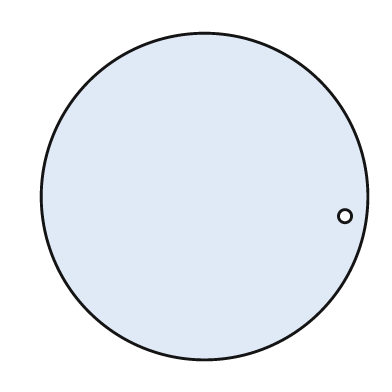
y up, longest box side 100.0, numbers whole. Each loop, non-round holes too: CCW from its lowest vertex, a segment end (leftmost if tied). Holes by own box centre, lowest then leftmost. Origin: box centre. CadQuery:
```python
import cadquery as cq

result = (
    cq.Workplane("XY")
    .moveTo(0.0, 0.0)
    .circle(50.0)
    .moveTo(43.0, -6.0)
    .circle(2.0)
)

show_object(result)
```